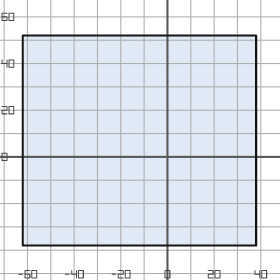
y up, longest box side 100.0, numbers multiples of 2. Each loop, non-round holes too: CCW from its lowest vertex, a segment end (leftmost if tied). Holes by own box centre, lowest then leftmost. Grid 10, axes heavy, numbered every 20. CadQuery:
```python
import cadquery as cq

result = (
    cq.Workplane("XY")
    .moveTo(-62.0, -38.0)
    .lineTo(38.0, -38.0)
    .lineTo(38.0, 52.0)
    .lineTo(-62.0, 52.0)
    .close()
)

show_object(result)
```